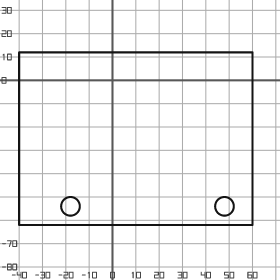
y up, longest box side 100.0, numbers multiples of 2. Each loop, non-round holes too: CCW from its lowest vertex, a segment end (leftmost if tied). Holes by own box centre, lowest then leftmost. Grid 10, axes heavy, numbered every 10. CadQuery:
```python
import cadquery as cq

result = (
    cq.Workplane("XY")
    .moveTo(-40.0, -62.0)
    .lineTo(60.0, -62.0)
    .lineTo(60.0, 12.0)
    .lineTo(-40.0, 12.0)
    .close()
    .moveTo(-18.0, -54.0)
    .circle(4.0)
    .moveTo(48.0, -54.0)
    .circle(4.0)
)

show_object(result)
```